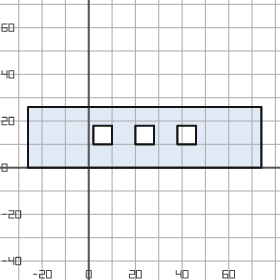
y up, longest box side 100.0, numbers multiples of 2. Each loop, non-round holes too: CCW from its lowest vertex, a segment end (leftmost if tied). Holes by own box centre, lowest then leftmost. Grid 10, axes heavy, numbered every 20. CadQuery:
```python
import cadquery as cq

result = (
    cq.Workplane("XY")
    .moveTo(-26.0, 0.0)
    .lineTo(74.0, 0.0)
    .lineTo(74.0, 26.0)
    .lineTo(-26.0, 26.0)
    .close()
    .moveTo(2.0, 10.0)
    .lineTo(10.0, 10.0)
    .lineTo(10.0, 18.0)
    .lineTo(2.0, 18.0)
    .close()
    .moveTo(20.0, 10.0)
    .lineTo(28.0, 10.0)
    .lineTo(28.0, 18.0)
    .lineTo(20.0, 18.0)
    .close()
    .moveTo(38.0, 10.0)
    .lineTo(46.0, 10.0)
    .lineTo(46.0, 18.0)
    .lineTo(38.0, 18.0)
    .close()
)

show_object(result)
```